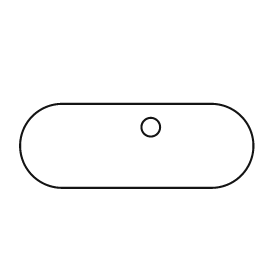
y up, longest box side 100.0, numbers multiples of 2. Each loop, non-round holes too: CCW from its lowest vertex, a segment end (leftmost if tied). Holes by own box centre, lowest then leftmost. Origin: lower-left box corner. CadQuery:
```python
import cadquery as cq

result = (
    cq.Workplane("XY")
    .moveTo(18.0, 0.0)
    .lineTo(82.0, 0.0)
    .threePointArc((100.0, 18.0), (82.0, 36.0))
    .lineTo(18.0, 36.0)
    .threePointArc((0.0, 18.0), (18.0, 0.0))
    .close()
    .moveTo(56.0, 26.0)
    .circle(4.0)
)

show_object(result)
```